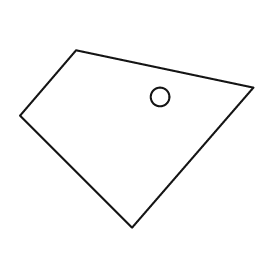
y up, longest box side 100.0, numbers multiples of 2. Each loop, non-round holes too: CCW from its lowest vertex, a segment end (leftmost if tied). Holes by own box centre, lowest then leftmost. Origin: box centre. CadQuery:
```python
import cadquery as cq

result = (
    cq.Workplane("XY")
    .moveTo(-2.0, -38.0)
    .lineTo(50.0, 22.0)
    .lineTo(-26.0, 38.0)
    .lineTo(-50.0, 10.0)
    .close()
    .moveTo(10.0, 18.0)
    .circle(4.0)
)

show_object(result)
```